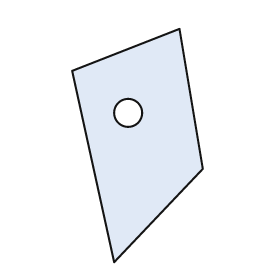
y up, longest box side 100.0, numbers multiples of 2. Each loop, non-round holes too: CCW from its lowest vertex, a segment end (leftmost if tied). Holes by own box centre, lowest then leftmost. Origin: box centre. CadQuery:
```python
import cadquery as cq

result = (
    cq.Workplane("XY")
    .moveTo(-10.0, -50.0)
    .lineTo(28.0, -10.0)
    .lineTo(18.0, 50.0)
    .lineTo(-28.0, 32.0)
    .close()
    .moveTo(-4.0, 14.0)
    .circle(6.0)
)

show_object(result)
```